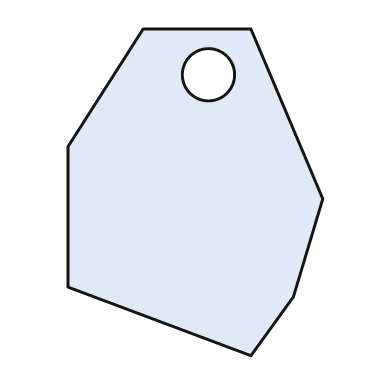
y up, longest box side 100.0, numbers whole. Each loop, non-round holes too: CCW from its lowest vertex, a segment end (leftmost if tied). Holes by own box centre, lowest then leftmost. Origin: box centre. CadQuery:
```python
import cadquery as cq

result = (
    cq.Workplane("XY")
    .moveTo(17.0, -50.0)
    .lineTo(30.0, -32.0)
    .lineTo(39.0, -2.0)
    .lineTo(17.0, 50.0)
    .lineTo(-16.0, 50.0)
    .lineTo(-39.0, 14.0)
    .lineTo(-39.0, -29.0)
    .close()
    .moveTo(4.0, 36.0)
    .circle(8.0)
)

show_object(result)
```